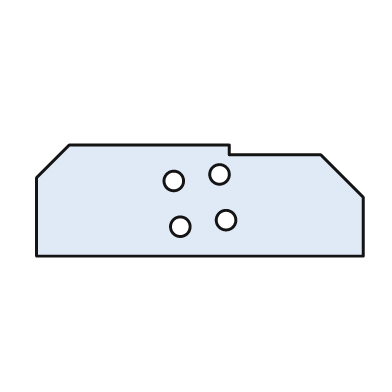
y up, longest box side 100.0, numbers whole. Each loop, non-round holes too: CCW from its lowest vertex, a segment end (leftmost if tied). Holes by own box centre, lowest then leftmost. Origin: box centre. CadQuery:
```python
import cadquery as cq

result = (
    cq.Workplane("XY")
    .moveTo(-50.0, -17.0)
    .lineTo(50.0, -17.0)
    .lineTo(50.0, 1.0)
    .lineTo(37.0, 14.0)
    .lineTo(9.0, 14.0)
    .lineTo(9.0, 17.0)
    .lineTo(-40.0, 17.0)
    .lineTo(-50.0, 7.0)
    .close()
    .moveTo(-6.0, -8.0)
    .circle(3.0)
    .moveTo(8.0, -6.0)
    .circle(3.0)
    .moveTo(-8.0, 6.0)
    .circle(3.0)
    .moveTo(6.0, 8.0)
    .circle(3.0)
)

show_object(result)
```